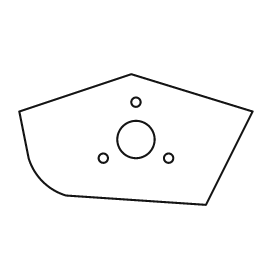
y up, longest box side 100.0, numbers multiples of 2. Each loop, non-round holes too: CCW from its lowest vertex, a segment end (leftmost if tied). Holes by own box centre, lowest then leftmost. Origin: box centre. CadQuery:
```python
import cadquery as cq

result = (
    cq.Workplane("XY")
    .moveTo(30.0, -28.0)
    .lineTo(50.0, 12.0)
    .lineTo(-2.0, 28.0)
    .lineTo(-50.0, 12.0)
    .lineTo(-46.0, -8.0)
    .threePointArc((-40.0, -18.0), (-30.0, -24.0))
    .close()
    .moveTo(-14.0, -8.0)
    .circle(2.0)
    .moveTo(14.0, -8.0)
    .circle(2.0)
    .moveTo(0.0, 0.0)
    .circle(8.0)
    .moveTo(0.0, 16.0)
    .circle(2.0)
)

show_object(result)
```